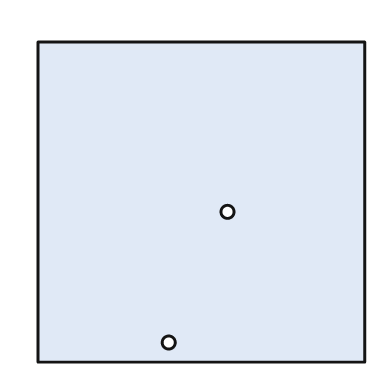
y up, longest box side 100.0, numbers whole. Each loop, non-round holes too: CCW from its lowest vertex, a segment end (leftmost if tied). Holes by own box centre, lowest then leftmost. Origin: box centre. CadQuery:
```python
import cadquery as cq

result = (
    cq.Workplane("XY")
    .moveTo(-50.0, -49.0)
    .lineTo(50.0, -49.0)
    .lineTo(50.0, 49.0)
    .lineTo(-50.0, 49.0)
    .close()
    .moveTo(-10.0, -43.0)
    .circle(2.0)
    .moveTo(8.0, -3.0)
    .circle(2.0)
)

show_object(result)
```